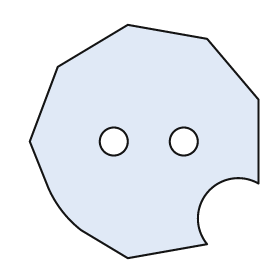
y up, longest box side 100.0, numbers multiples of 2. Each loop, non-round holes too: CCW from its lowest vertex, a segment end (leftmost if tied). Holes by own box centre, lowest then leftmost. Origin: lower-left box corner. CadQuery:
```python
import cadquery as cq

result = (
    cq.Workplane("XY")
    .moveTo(42.0, 0.0)
    .lineTo(76.0, 6.0)
    .threePointArc((76.0, 28.0), (98.0, 32.0))
    .lineTo(98.0, 68.0)
    .lineTo(76.0, 94.0)
    .lineTo(42.0, 100.0)
    .lineTo(12.0, 82.0)
    .lineTo(0.0, 50.0)
    .lineTo(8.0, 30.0)
    .threePointArc((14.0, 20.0), (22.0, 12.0))
    .close()
    .moveTo(36.0, 50.0)
    .circle(6.0)
    .moveTo(66.0, 50.0)
    .circle(6.0)
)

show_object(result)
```